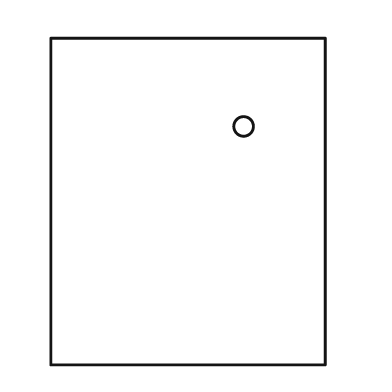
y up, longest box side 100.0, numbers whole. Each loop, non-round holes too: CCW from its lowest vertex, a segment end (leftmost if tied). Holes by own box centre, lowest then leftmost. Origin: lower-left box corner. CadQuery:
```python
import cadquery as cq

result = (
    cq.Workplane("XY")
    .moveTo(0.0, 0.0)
    .lineTo(84.0, 0.0)
    .lineTo(84.0, 100.0)
    .lineTo(0.0, 100.0)
    .close()
    .moveTo(59.0, 73.0)
    .circle(3.0)
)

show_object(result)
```